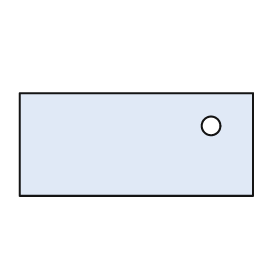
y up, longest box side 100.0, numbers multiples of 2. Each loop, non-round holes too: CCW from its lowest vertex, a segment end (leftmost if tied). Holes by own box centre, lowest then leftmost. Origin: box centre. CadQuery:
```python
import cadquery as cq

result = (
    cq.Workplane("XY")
    .moveTo(-50.0, -22.0)
    .lineTo(50.0, -22.0)
    .lineTo(50.0, 22.0)
    .lineTo(-50.0, 22.0)
    .close()
    .moveTo(32.0, 8.0)
    .circle(4.0)
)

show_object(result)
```